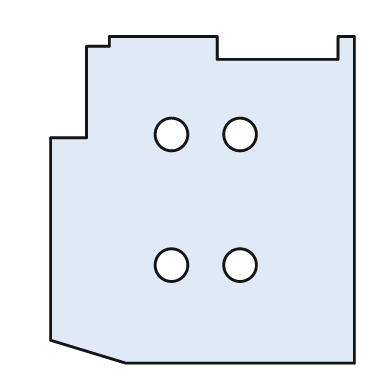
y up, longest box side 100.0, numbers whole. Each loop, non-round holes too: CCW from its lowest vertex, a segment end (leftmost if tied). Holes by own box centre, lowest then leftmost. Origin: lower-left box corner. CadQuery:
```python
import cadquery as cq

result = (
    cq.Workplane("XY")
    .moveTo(23.0, 0.0)
    .lineTo(93.0, 0.0)
    .lineTo(93.0, 100.0)
    .lineTo(88.0, 100.0)
    .lineTo(88.0, 93.0)
    .lineTo(51.0, 93.0)
    .lineTo(51.0, 100.0)
    .lineTo(18.0, 100.0)
    .lineTo(18.0, 97.0)
    .lineTo(11.0, 97.0)
    .lineTo(11.0, 69.0)
    .lineTo(0.0, 69.0)
    .lineTo(0.0, 7.0)
    .close()
    .moveTo(37.0, 30.0)
    .circle(5.0)
    .moveTo(58.0, 30.0)
    .circle(5.0)
    .moveTo(37.0, 70.0)
    .circle(5.0)
    .moveTo(58.0, 70.0)
    .circle(5.0)
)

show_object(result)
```